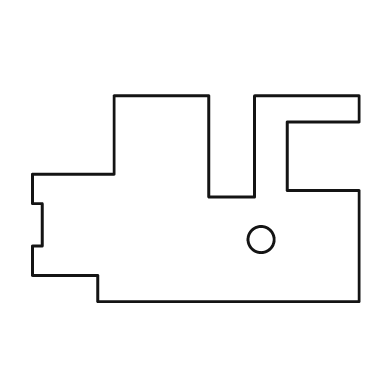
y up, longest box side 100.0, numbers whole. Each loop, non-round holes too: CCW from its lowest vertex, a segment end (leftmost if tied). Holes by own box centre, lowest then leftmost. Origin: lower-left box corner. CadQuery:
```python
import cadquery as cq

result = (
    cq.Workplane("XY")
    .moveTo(20.0, 0.0)
    .lineTo(100.0, 0.0)
    .lineTo(100.0, 34.0)
    .lineTo(78.0, 34.0)
    .lineTo(78.0, 55.0)
    .lineTo(100.0, 55.0)
    .lineTo(100.0, 63.0)
    .lineTo(68.0, 63.0)
    .lineTo(68.0, 32.0)
    .lineTo(54.0, 32.0)
    .lineTo(54.0, 63.0)
    .lineTo(25.0, 63.0)
    .lineTo(25.0, 39.0)
    .lineTo(0.0, 39.0)
    .lineTo(0.0, 30.0)
    .lineTo(3.0, 30.0)
    .lineTo(3.0, 17.0)
    .lineTo(0.0, 17.0)
    .lineTo(0.0, 8.0)
    .lineTo(20.0, 8.0)
    .close()
    .moveTo(70.0, 19.0)
    .circle(4.0)
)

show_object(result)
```